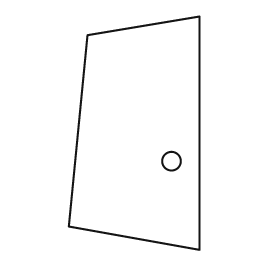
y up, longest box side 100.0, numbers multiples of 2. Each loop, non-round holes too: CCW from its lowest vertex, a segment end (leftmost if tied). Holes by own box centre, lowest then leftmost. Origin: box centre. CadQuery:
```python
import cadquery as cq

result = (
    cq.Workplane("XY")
    .moveTo(28.0, -50.0)
    .lineTo(28.0, 50.0)
    .lineTo(-20.0, 42.0)
    .lineTo(-28.0, -40.0)
    .close()
    .moveTo(16.0, -12.0)
    .circle(4.0)
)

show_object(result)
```